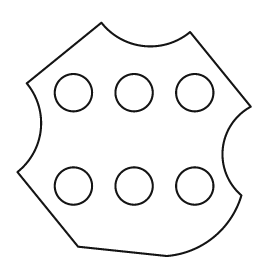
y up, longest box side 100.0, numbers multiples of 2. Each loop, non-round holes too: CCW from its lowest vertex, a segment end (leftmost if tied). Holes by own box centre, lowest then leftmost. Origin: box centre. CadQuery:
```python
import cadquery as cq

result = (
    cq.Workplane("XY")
    .moveTo(14.0, -50.0)
    .threePointArc((34.0, -42.0), (46.0, -24.0))
    .threePointArc((38.0, -4.0), (50.0, 14.0))
    .lineTo(24.0, 46.0)
    .threePointArc((4.0, 40.0), (-14.0, 50.0))
    .lineTo(-46.0, 24.0)
    .threePointArc((-40.0, 4.0), (-50.0, -14.0))
    .lineTo(-24.0, -46.0)
    .close()
    .moveTo(-26.0, -20.0)
    .circle(8.0)
    .moveTo(0.0, -20.0)
    .circle(8.0)
    .moveTo(26.0, -20.0)
    .circle(8.0)
    .moveTo(-26.0, 20.0)
    .circle(8.0)
    .moveTo(0.0, 20.0)
    .circle(8.0)
    .moveTo(26.0, 20.0)
    .circle(8.0)
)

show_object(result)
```